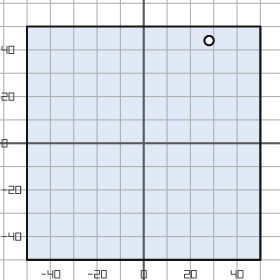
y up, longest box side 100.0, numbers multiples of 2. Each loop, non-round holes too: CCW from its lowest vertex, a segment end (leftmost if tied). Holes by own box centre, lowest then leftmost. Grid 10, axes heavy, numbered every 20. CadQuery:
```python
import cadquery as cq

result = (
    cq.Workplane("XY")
    .moveTo(-50.0, -50.0)
    .lineTo(50.0, -50.0)
    .lineTo(50.0, 50.0)
    .lineTo(-50.0, 50.0)
    .close()
    .moveTo(28.0, 44.0)
    .circle(2.0)
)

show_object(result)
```